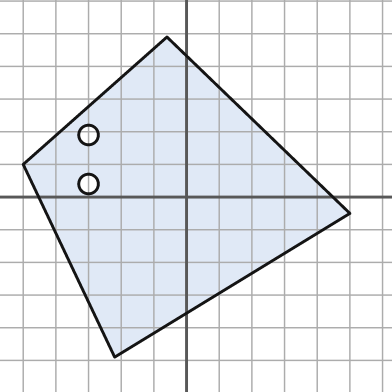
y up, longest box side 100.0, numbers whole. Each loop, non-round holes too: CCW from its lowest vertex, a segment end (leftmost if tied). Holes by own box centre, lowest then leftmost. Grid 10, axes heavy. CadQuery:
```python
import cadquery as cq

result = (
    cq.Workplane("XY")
    .moveTo(-22.0, -49.0)
    .lineTo(50.0, -5.0)
    .lineTo(-6.0, 49.0)
    .lineTo(-50.0, 10.0)
    .close()
    .moveTo(-30.0, 4.0)
    .circle(3.0)
    .moveTo(-30.0, 19.0)
    .circle(3.0)
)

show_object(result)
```